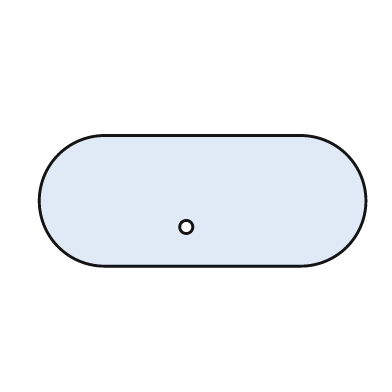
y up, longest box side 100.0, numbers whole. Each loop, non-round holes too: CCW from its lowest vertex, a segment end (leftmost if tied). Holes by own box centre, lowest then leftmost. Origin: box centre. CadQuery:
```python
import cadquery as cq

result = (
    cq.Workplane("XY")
    .moveTo(-30.0, -20.0)
    .lineTo(30.0, -20.0)
    .threePointArc((50.0, 0.0), (30.0, 20.0))
    .lineTo(-30.0, 20.0)
    .threePointArc((-50.0, 0.0), (-30.0, -20.0))
    .close()
    .moveTo(-5.0, -8.0)
    .circle(2.0)
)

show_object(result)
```